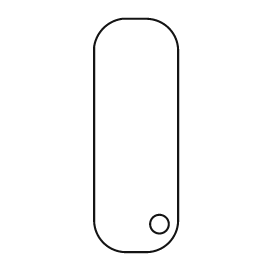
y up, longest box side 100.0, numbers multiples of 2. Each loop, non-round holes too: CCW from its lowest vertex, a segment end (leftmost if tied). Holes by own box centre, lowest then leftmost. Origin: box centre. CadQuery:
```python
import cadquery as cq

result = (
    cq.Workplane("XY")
    .moveTo(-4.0, -50.0)
    .lineTo(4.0, -50.0)
    .threePointArc((14.0, -46.0), (18.0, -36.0))
    .lineTo(18.0, 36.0)
    .threePointArc((14.0, 46.0), (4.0, 50.0))
    .lineTo(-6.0, 50.0)
    .threePointArc((-14.0, 46.0), (-18.0, 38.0))
    .lineTo(-18.0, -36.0)
    .threePointArc((-14.0, -46.0), (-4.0, -50.0))
    .close()
    .moveTo(10.0, -38.0)
    .circle(4.0)
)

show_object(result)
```